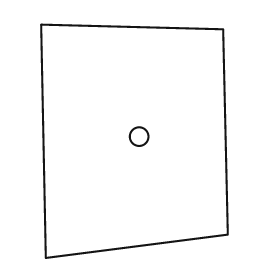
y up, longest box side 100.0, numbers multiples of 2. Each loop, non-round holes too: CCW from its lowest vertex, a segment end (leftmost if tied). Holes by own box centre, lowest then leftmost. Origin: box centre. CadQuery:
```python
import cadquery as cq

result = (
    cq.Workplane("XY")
    .moveTo(-38.0, -50.0)
    .lineTo(40.0, -40.0)
    .lineTo(38.0, 48.0)
    .lineTo(-40.0, 50.0)
    .close()
    .moveTo(2.0, 2.0)
    .circle(4.0)
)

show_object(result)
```